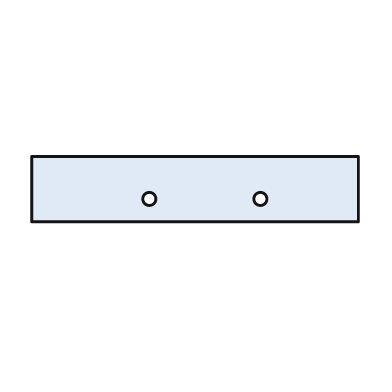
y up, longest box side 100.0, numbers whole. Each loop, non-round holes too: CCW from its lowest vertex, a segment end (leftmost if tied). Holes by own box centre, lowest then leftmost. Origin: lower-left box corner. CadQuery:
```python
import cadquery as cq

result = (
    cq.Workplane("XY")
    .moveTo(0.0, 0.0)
    .lineTo(100.0, 0.0)
    .lineTo(100.0, 20.0)
    .lineTo(0.0, 20.0)
    .close()
    .moveTo(36.0, 7.0)
    .circle(2.0)
    .moveTo(70.0, 7.0)
    .circle(2.0)
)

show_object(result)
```